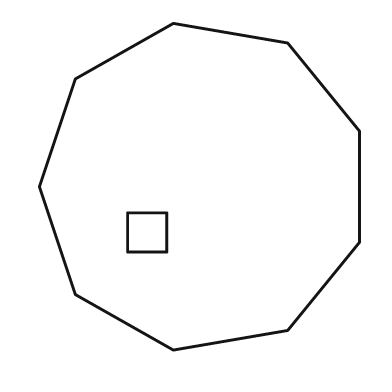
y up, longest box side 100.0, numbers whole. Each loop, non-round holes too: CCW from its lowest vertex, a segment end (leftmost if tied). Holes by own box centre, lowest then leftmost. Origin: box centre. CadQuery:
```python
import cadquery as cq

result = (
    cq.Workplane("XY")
    .moveTo(-8.0, -50.0)
    .lineTo(27.0, -44.0)
    .lineTo(49.0, -17.0)
    .lineTo(49.0, 17.0)
    .lineTo(27.0, 44.0)
    .lineTo(-8.0, 50.0)
    .lineTo(-38.0, 33.0)
    .lineTo(-49.0, 0.0)
    .lineTo(-38.0, -33.0)
    .close()
    .moveTo(-22.0, -20.0)
    .lineTo(-10.0, -20.0)
    .lineTo(-10.0, -8.0)
    .lineTo(-22.0, -8.0)
    .close()
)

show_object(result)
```